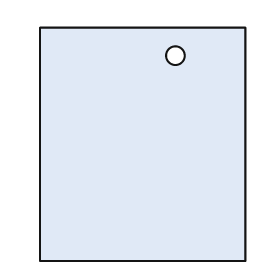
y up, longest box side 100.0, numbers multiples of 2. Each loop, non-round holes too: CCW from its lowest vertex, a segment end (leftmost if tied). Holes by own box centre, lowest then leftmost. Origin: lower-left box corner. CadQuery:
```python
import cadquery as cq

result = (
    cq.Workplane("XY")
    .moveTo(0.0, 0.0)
    .lineTo(88.0, 0.0)
    .lineTo(88.0, 100.0)
    .lineTo(0.0, 100.0)
    .close()
    .moveTo(58.0, 88.0)
    .circle(4.0)
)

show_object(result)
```